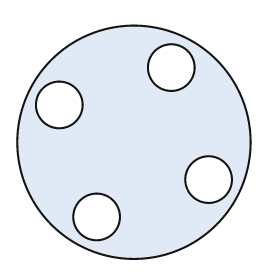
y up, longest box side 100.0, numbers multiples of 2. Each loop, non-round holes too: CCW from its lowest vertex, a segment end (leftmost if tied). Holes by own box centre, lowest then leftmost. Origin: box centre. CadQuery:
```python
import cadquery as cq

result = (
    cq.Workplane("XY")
    .moveTo(0.0, 0.0)
    .circle(50.0)
    .moveTo(-16.0, -32.0)
    .circle(10.0)
    .moveTo(32.0, -16.0)
    .circle(10.0)
    .moveTo(-32.0, 16.0)
    .circle(10.0)
    .moveTo(16.0, 32.0)
    .circle(10.0)
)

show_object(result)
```